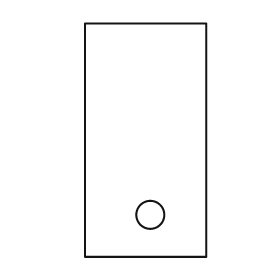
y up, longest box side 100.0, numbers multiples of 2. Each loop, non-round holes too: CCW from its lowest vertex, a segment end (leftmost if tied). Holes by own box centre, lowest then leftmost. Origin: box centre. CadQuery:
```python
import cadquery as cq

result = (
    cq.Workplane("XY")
    .moveTo(-26.0, -50.0)
    .lineTo(26.0, -50.0)
    .lineTo(26.0, 50.0)
    .lineTo(-26.0, 50.0)
    .close()
    .moveTo(2.0, -32.0)
    .circle(6.0)
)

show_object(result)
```